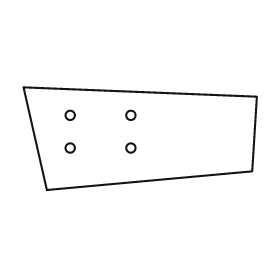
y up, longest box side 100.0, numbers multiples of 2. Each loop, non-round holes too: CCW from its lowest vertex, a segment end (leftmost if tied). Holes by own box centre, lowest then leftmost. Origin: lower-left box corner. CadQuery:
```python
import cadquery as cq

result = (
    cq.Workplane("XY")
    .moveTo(10.0, 0.0)
    .lineTo(98.0, 8.0)
    .lineTo(100.0, 40.0)
    .lineTo(0.0, 44.0)
    .close()
    .moveTo(20.0, 18.0)
    .circle(2.0)
    .moveTo(46.0, 18.0)
    .circle(2.0)
    .moveTo(20.0, 32.0)
    .circle(2.0)
    .moveTo(46.0, 32.0)
    .circle(2.0)
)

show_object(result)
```